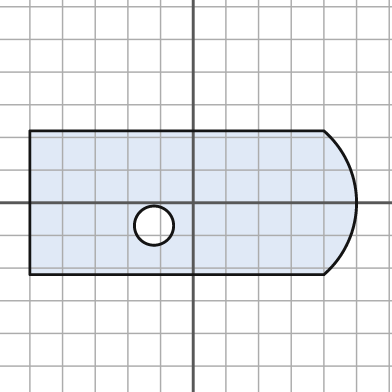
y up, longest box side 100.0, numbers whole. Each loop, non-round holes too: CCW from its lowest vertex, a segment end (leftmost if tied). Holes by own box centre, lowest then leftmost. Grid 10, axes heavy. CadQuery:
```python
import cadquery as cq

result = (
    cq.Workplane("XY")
    .moveTo(-50.0, -22.0)
    .lineTo(40.0, -22.0)
    .threePointArc((50.0, 0.0), (40.0, 22.0))
    .lineTo(-50.0, 22.0)
    .close()
    .moveTo(-12.0, -7.0)
    .circle(6.0)
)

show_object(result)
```